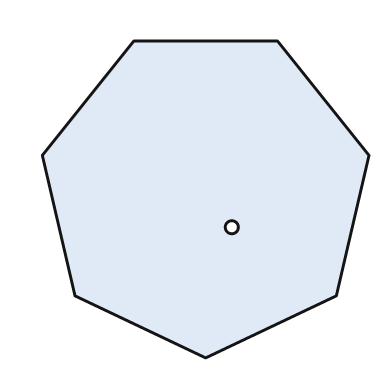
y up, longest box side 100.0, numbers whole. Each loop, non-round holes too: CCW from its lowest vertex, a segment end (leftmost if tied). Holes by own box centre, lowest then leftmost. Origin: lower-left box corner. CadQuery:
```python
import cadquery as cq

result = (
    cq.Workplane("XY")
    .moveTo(50.0, 0.0)
    .lineTo(90.0, 19.0)
    .lineTo(100.0, 62.0)
    .lineTo(72.0, 97.0)
    .lineTo(28.0, 97.0)
    .lineTo(0.0, 62.0)
    .lineTo(10.0, 19.0)
    .close()
    .moveTo(58.0, 40.0)
    .circle(2.0)
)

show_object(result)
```